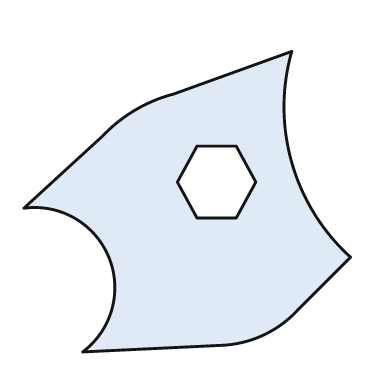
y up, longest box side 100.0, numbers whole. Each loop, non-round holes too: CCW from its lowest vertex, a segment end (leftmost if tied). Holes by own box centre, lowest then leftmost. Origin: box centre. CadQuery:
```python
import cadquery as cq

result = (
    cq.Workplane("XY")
    .moveTo(-32.0, -46.0)
    .lineTo(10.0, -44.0)
    .threePointArc((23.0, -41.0), (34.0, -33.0))
    .lineTo(50.0, -17.0)
    .threePointArc((32.0, 12.0), (32.0, 46.0))
    .lineTo(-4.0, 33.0)
    .threePointArc((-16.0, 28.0), (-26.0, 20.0))
    .lineTo(-50.0, -2.0)
    .threePointArc((-24.0, -17.0), (-32.0, -46.0))
    .close()
    .moveTo(3.0, -5.0)
    .lineTo(15.0, -5.0)
    .lineTo(21.0, 6.0)
    .lineTo(15.0, 17.0)
    .lineTo(3.0, 17.0)
    .lineTo(-3.0, 6.0)
    .close()
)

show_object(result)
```